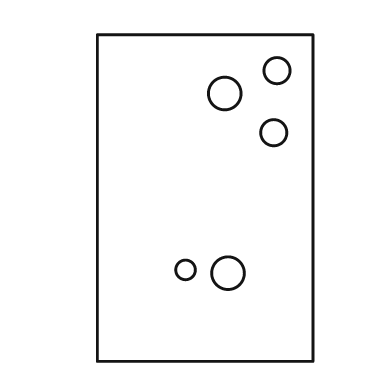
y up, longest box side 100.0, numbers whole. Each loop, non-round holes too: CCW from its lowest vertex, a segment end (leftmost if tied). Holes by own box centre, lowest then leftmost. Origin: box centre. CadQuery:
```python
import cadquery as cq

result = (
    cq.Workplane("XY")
    .moveTo(-33.0, -50.0)
    .lineTo(33.0, -50.0)
    .lineTo(33.0, 50.0)
    .lineTo(-33.0, 50.0)
    .close()
    .moveTo(7.0, -23.0)
    .circle(5.0)
    .moveTo(-6.0, -22.0)
    .circle(3.0)
    .moveTo(21.0, 20.0)
    .circle(4.0)
    .moveTo(6.0, 32.0)
    .circle(5.0)
    .moveTo(22.0, 39.0)
    .circle(4.0)
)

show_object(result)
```